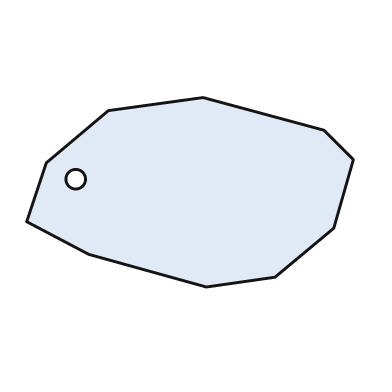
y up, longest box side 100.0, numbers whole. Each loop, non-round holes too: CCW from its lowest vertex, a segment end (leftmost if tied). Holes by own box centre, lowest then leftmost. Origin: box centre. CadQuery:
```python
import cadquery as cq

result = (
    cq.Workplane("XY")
    .moveTo(5.0, -29.0)
    .lineTo(26.0, -26.0)
    .lineTo(44.0, -11.0)
    .lineTo(50.0, 10.0)
    .lineTo(41.0, 19.0)
    .lineTo(4.0, 29.0)
    .lineTo(-25.0, 25.0)
    .lineTo(-44.0, 9.0)
    .lineTo(-50.0, -9.0)
    .lineTo(-31.0, -19.0)
    .close()
    .moveTo(-35.0, 4.0)
    .circle(3.0)
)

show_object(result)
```